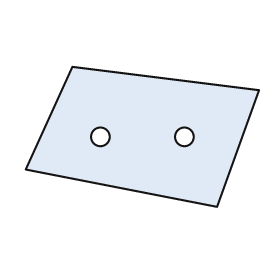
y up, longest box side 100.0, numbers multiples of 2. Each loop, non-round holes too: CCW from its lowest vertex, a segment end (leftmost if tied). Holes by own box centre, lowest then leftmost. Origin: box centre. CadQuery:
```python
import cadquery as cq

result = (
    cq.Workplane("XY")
    .moveTo(32.0, -30.0)
    .lineTo(50.0, 20.0)
    .lineTo(-30.0, 30.0)
    .lineTo(-50.0, -14.0)
    .close()
    .moveTo(-18.0, 0.0)
    .circle(4.0)
    .moveTo(18.0, 0.0)
    .circle(4.0)
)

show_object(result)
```